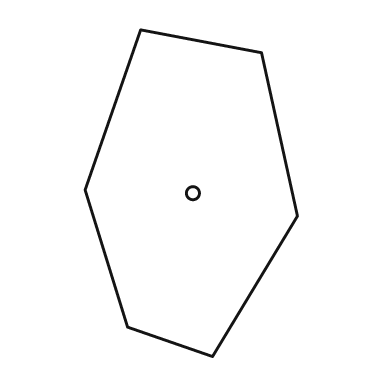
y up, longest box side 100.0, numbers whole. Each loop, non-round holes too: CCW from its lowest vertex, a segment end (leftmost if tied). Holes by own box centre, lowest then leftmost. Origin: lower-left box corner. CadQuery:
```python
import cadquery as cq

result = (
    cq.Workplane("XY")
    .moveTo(39.0, 0.0)
    .lineTo(65.0, 43.0)
    .lineTo(54.0, 93.0)
    .lineTo(17.0, 100.0)
    .lineTo(0.0, 51.0)
    .lineTo(13.0, 9.0)
    .close()
    .moveTo(33.0, 50.0)
    .circle(2.0)
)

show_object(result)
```